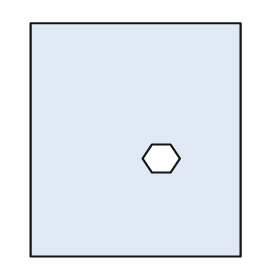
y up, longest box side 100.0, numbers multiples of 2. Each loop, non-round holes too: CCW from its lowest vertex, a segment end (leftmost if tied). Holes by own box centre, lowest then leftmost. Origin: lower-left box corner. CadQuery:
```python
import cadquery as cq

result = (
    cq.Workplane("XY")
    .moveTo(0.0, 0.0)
    .lineTo(90.0, 0.0)
    .lineTo(90.0, 100.0)
    .lineTo(0.0, 100.0)
    .close()
    .moveTo(52.0, 36.0)
    .lineTo(60.0, 36.0)
    .lineTo(64.0, 42.0)
    .lineTo(60.0, 48.0)
    .lineTo(52.0, 48.0)
    .lineTo(48.0, 42.0)
    .close()
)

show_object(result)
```